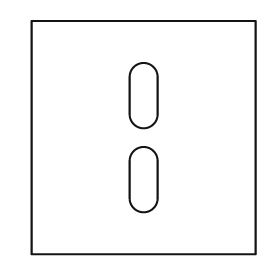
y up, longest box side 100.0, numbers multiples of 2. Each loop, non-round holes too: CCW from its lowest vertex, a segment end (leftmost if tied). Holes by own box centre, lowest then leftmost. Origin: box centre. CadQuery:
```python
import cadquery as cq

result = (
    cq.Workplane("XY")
    .moveTo(-48.0, -50.0)
    .lineTo(48.0, -50.0)
    .lineTo(48.0, 50.0)
    .lineTo(-48.0, 50.0)
    .close()
    .moveTo(-6.0, -26.0)
    .threePointArc((0.0, -32.0), (6.0, -26.0))
    .lineTo(6.0, -10.0)
    .threePointArc((0.0, -4.0), (-6.0, -10.0))
    .close()
    .moveTo(-6.0, 10.0)
    .threePointArc((0.0, 4.0), (6.0, 10.0))
    .lineTo(6.0, 26.0)
    .threePointArc((0.0, 32.0), (-6.0, 26.0))
    .close()
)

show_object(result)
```